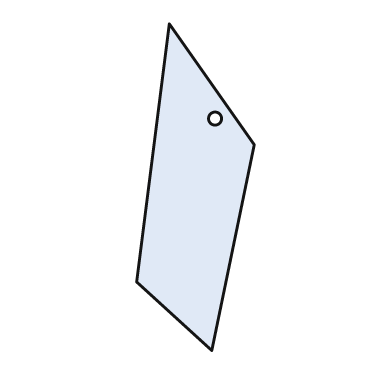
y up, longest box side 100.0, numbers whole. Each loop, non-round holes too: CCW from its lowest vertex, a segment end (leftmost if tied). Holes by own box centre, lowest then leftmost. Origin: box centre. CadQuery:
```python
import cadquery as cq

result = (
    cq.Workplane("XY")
    .moveTo(5.0, -50.0)
    .lineTo(18.0, 13.0)
    .lineTo(-8.0, 50.0)
    .lineTo(-18.0, -29.0)
    .close()
    .moveTo(6.0, 21.0)
    .circle(2.0)
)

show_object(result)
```